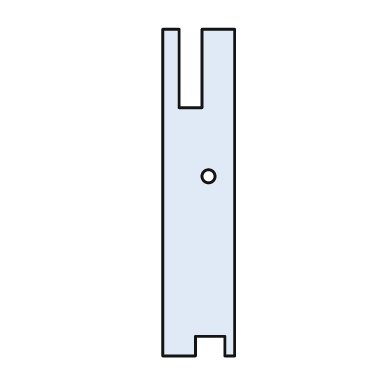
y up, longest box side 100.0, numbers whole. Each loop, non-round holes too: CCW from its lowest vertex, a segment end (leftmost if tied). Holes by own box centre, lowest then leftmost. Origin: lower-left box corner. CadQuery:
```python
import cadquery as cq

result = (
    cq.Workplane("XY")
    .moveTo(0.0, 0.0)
    .lineTo(10.0, 0.0)
    .lineTo(10.0, 6.0)
    .lineTo(19.0, 6.0)
    .lineTo(19.0, 0.0)
    .lineTo(22.0, 0.0)
    .lineTo(22.0, 100.0)
    .lineTo(12.0, 100.0)
    .lineTo(12.0, 76.0)
    .lineTo(5.0, 76.0)
    .lineTo(5.0, 100.0)
    .lineTo(0.0, 100.0)
    .close()
    .moveTo(14.0, 55.0)
    .circle(2.0)
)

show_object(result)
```